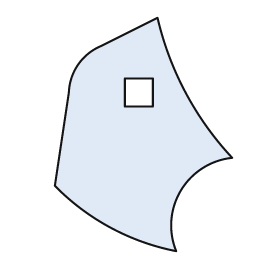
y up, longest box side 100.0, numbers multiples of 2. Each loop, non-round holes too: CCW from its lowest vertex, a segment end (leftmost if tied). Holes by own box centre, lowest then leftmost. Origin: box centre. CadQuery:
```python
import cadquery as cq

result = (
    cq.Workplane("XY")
    .moveTo(14.0, -50.0)
    .threePointArc((16.0, -24.0), (38.0, -10.0))
    .threePointArc((18.0, 18.0), (6.0, 50.0))
    .lineTo(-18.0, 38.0)
    .threePointArc((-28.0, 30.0), (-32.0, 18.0))
    .lineTo(-38.0, -22.0)
    .threePointArc((-14.0, -40.0), (14.0, -50.0))
    .close()
    .moveTo(-8.0, 12.0)
    .lineTo(4.0, 12.0)
    .lineTo(4.0, 24.0)
    .lineTo(-8.0, 24.0)
    .close()
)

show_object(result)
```